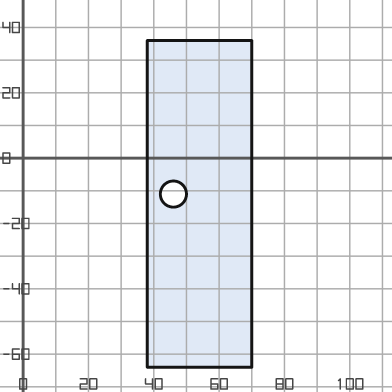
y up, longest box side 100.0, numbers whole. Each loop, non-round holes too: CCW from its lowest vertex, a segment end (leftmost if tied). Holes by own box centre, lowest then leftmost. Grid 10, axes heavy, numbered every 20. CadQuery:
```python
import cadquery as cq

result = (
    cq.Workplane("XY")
    .moveTo(38.0, -64.0)
    .lineTo(70.0, -64.0)
    .lineTo(70.0, 36.0)
    .lineTo(38.0, 36.0)
    .close()
    .moveTo(46.0, -11.0)
    .circle(4.0)
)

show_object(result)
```